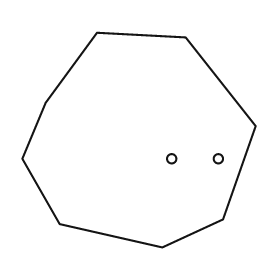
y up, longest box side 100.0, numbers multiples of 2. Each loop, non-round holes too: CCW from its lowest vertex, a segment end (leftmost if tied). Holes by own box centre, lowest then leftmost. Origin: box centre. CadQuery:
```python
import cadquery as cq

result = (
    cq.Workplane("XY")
    .moveTo(10.0, -46.0)
    .lineTo(36.0, -34.0)
    .lineTo(50.0, 6.0)
    .lineTo(20.0, 44.0)
    .lineTo(-18.0, 46.0)
    .lineTo(-40.0, 16.0)
    .lineTo(-50.0, -8.0)
    .lineTo(-34.0, -36.0)
    .close()
    .moveTo(14.0, -8.0)
    .circle(2.0)
    .moveTo(34.0, -8.0)
    .circle(2.0)
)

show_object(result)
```